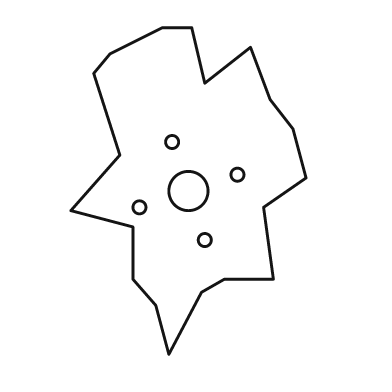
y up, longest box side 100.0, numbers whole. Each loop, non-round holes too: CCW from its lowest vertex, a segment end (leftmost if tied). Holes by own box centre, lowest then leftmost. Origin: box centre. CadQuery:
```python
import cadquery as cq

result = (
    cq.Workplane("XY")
    .moveTo(-6.0, -50.0)
    .lineTo(4.0, -31.0)
    .lineTo(11.0, -27.0)
    .lineTo(26.0, -27.0)
    .lineTo(23.0, -5.0)
    .lineTo(36.0, 4.0)
    .lineTo(32.0, 19.0)
    .lineTo(25.0, 28.0)
    .lineTo(19.0, 44.0)
    .lineTo(5.0, 33.0)
    .lineTo(1.0, 50.0)
    .lineTo(-8.0, 50.0)
    .lineTo(-24.0, 42.0)
    .lineTo(-29.0, 36.0)
    .lineTo(-21.0, 11.0)
    .lineTo(-36.0, -6.0)
    .lineTo(-17.0, -11.0)
    .lineTo(-17.0, -27.0)
    .lineTo(-10.0, -35.0)
    .close()
    .moveTo(5.0, -15.0)
    .circle(2.0)
    .moveTo(-15.0, -5.0)
    .circle(2.0)
    .moveTo(0.0, 0.0)
    .circle(6.0)
    .moveTo(15.0, 5.0)
    .circle(2.0)
    .moveTo(-5.0, 15.0)
    .circle(2.0)
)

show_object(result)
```